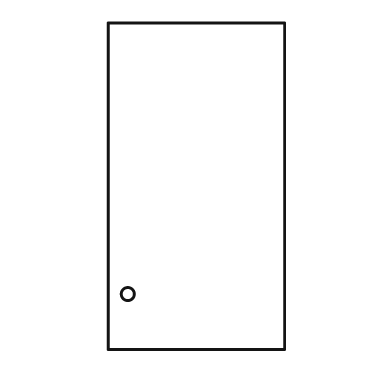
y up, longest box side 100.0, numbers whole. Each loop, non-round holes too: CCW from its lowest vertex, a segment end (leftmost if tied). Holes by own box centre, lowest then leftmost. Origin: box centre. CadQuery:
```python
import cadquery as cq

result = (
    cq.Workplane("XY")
    .moveTo(-27.0, -50.0)
    .lineTo(27.0, -50.0)
    .lineTo(27.0, 50.0)
    .lineTo(-27.0, 50.0)
    .close()
    .moveTo(-21.0, -33.0)
    .circle(2.0)
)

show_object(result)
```